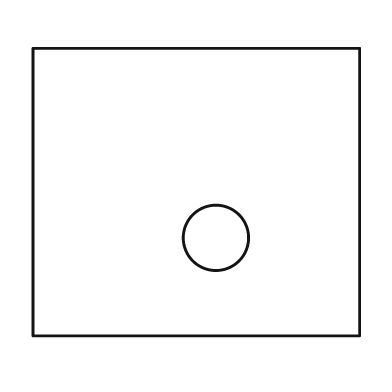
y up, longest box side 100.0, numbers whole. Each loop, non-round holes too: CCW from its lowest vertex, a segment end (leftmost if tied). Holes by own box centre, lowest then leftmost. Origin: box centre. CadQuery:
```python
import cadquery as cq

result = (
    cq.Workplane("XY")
    .moveTo(-50.0, -44.0)
    .lineTo(50.0, -44.0)
    .lineTo(50.0, 44.0)
    .lineTo(-50.0, 44.0)
    .close()
    .moveTo(6.0, -14.0)
    .circle(10.0)
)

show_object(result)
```